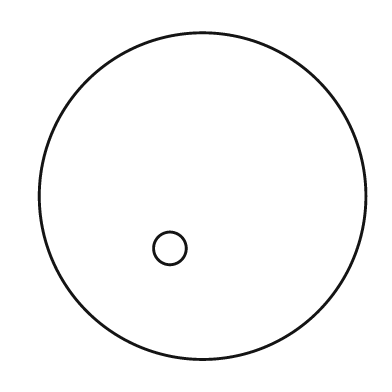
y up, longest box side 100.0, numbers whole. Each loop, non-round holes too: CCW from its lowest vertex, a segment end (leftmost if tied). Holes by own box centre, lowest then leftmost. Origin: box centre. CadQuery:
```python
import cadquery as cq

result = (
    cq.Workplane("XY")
    .moveTo(0.0, 0.0)
    .circle(50.0)
    .moveTo(-10.0, -16.0)
    .circle(5.0)
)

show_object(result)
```